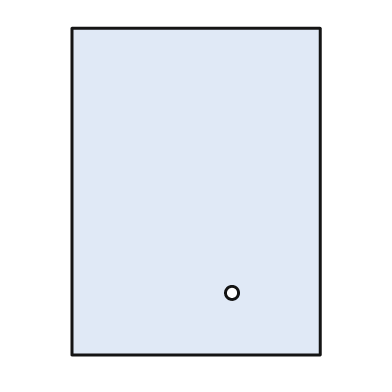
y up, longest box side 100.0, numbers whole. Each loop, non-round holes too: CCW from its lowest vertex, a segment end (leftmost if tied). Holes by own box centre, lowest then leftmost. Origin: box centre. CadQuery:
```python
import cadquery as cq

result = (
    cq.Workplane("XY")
    .moveTo(-38.0, -50.0)
    .lineTo(38.0, -50.0)
    .lineTo(38.0, 50.0)
    .lineTo(-38.0, 50.0)
    .close()
    .moveTo(11.0, -31.0)
    .circle(2.0)
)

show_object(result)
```